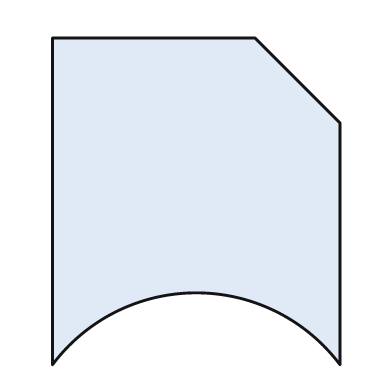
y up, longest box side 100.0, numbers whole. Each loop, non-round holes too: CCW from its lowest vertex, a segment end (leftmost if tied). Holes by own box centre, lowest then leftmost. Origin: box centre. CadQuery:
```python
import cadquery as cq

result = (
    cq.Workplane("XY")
    .moveTo(-44.0, -50.0)
    .threePointArc((0.0, -28.0), (44.0, -50.0))
    .lineTo(44.0, 24.0)
    .lineTo(18.0, 50.0)
    .lineTo(-44.0, 50.0)
    .close()
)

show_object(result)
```